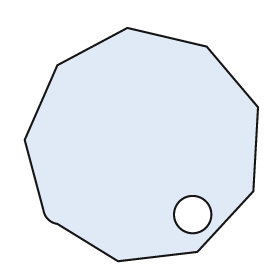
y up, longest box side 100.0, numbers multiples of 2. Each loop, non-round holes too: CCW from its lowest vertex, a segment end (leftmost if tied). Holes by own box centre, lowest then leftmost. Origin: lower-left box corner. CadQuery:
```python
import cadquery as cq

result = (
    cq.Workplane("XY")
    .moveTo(40.0, 0.0)
    .lineTo(74.0, 4.0)
    .lineTo(98.0, 30.0)
    .lineTo(100.0, 66.0)
    .lineTo(78.0, 92.0)
    .lineTo(44.0, 100.0)
    .lineTo(14.0, 84.0)
    .lineTo(0.0, 52.0)
    .lineTo(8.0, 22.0)
    .threePointArc((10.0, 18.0), (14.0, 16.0))
    .close()
    .moveTo(72.0, 20.0)
    .circle(8.0)
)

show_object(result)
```